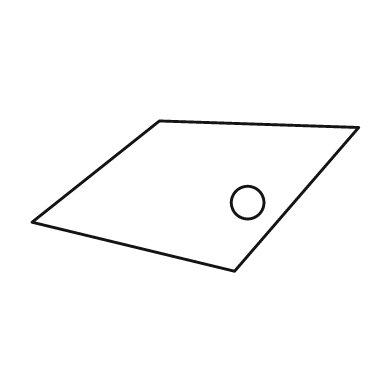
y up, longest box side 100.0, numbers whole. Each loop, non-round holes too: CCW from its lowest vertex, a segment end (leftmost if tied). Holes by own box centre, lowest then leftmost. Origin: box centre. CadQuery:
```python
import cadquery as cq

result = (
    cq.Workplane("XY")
    .moveTo(12.0, -23.0)
    .lineTo(50.0, 21.0)
    .lineTo(-11.0, 23.0)
    .lineTo(-50.0, -8.0)
    .close()
    .moveTo(16.0, -2.0)
    .circle(5.0)
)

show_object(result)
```